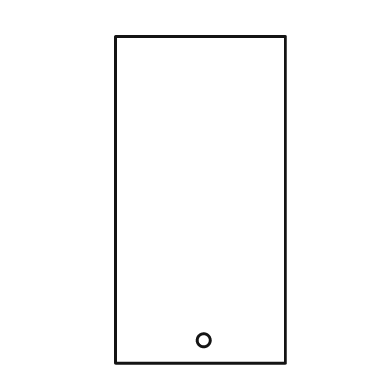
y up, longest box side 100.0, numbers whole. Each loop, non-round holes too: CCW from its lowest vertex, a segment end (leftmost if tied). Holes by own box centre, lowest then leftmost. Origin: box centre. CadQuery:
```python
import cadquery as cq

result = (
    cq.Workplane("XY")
    .moveTo(-26.0, -50.0)
    .lineTo(26.0, -50.0)
    .lineTo(26.0, 50.0)
    .lineTo(-26.0, 50.0)
    .close()
    .moveTo(1.0, -43.0)
    .circle(2.0)
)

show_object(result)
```